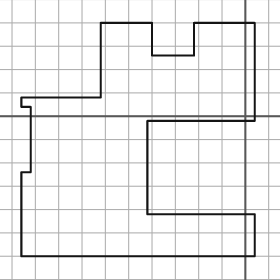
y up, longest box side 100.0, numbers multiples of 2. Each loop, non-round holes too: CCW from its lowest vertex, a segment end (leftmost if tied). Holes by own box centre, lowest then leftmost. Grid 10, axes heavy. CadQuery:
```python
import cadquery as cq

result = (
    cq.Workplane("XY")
    .moveTo(-96.0, -60.0)
    .lineTo(4.0, -60.0)
    .lineTo(4.0, -42.0)
    .lineTo(-42.0, -42.0)
    .lineTo(-42.0, -2.0)
    .lineTo(4.0, -2.0)
    .lineTo(4.0, 40.0)
    .lineTo(-22.0, 40.0)
    .lineTo(-22.0, 26.0)
    .lineTo(-40.0, 26.0)
    .lineTo(-40.0, 40.0)
    .lineTo(-62.0, 40.0)
    .lineTo(-62.0, 8.0)
    .lineTo(-96.0, 8.0)
    .lineTo(-96.0, 4.0)
    .lineTo(-92.0, 4.0)
    .lineTo(-92.0, -24.0)
    .lineTo(-96.0, -24.0)
    .close()
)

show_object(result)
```